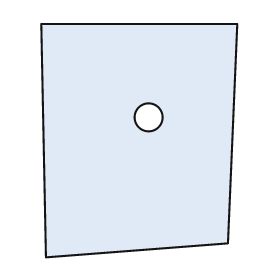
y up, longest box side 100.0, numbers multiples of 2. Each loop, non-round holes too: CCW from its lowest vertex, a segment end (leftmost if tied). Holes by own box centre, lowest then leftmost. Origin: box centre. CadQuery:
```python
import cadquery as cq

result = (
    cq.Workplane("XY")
    .moveTo(-40.0, -50.0)
    .lineTo(38.0, -44.0)
    .lineTo(42.0, 50.0)
    .lineTo(-42.0, 50.0)
    .close()
    .moveTo(4.0, 10.0)
    .circle(6.0)
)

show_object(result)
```